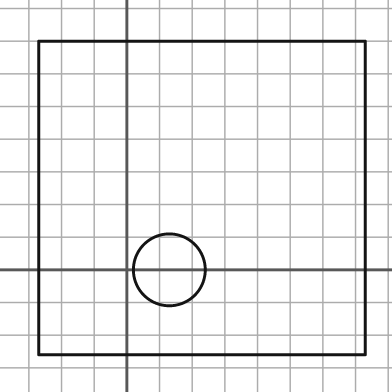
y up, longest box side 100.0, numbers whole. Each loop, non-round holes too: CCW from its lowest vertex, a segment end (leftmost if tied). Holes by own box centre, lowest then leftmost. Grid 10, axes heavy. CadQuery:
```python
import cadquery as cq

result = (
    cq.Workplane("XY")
    .moveTo(-27.0, -26.0)
    .lineTo(73.0, -26.0)
    .lineTo(73.0, 70.0)
    .lineTo(-27.0, 70.0)
    .close()
    .moveTo(13.0, 0.0)
    .circle(11.0)
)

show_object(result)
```